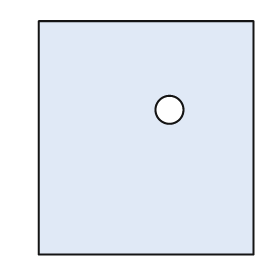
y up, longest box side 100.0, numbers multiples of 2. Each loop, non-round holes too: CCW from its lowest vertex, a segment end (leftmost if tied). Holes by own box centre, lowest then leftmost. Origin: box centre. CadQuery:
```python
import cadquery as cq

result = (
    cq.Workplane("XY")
    .moveTo(-46.0, -50.0)
    .lineTo(46.0, -50.0)
    .lineTo(46.0, 50.0)
    .lineTo(-46.0, 50.0)
    .close()
    .moveTo(10.0, 12.0)
    .circle(6.0)
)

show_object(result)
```